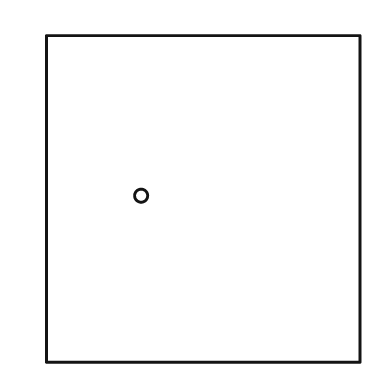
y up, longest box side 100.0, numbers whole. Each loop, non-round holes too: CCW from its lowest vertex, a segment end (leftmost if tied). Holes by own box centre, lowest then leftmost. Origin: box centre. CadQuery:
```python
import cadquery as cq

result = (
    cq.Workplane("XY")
    .moveTo(-48.0, -50.0)
    .lineTo(48.0, -50.0)
    .lineTo(48.0, 50.0)
    .lineTo(-48.0, 50.0)
    .close()
    .moveTo(-19.0, 1.0)
    .circle(2.0)
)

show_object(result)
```